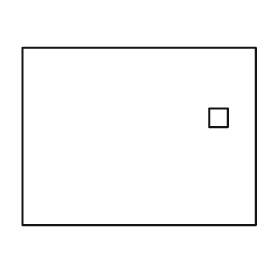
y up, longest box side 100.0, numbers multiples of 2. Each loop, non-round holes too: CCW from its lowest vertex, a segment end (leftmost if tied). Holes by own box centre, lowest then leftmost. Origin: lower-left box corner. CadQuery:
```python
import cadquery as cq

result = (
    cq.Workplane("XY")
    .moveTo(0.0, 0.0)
    .lineTo(100.0, 0.0)
    .lineTo(100.0, 76.0)
    .lineTo(0.0, 76.0)
    .close()
    .moveTo(80.0, 42.0)
    .lineTo(88.0, 42.0)
    .lineTo(88.0, 50.0)
    .lineTo(80.0, 50.0)
    .close()
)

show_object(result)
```